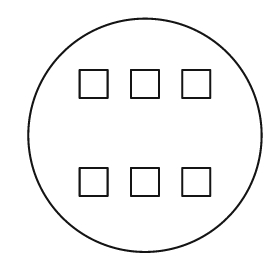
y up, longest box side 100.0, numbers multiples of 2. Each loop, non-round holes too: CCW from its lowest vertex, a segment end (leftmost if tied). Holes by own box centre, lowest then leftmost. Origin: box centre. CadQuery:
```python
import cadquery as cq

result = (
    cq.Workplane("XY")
    .moveTo(0.0, 0.0)
    .circle(50.0)
    .moveTo(-28.0, -26.0)
    .lineTo(-16.0, -26.0)
    .lineTo(-16.0, -14.0)
    .lineTo(-28.0, -14.0)
    .close()
    .moveTo(-6.0, -26.0)
    .lineTo(6.0, -26.0)
    .lineTo(6.0, -14.0)
    .lineTo(-6.0, -14.0)
    .close()
    .moveTo(16.0, -26.0)
    .lineTo(28.0, -26.0)
    .lineTo(28.0, -14.0)
    .lineTo(16.0, -14.0)
    .close()
    .moveTo(-28.0, 16.0)
    .lineTo(-16.0, 16.0)
    .lineTo(-16.0, 28.0)
    .lineTo(-28.0, 28.0)
    .close()
    .moveTo(-6.0, 16.0)
    .lineTo(6.0, 16.0)
    .lineTo(6.0, 28.0)
    .lineTo(-6.0, 28.0)
    .close()
    .moveTo(16.0, 16.0)
    .lineTo(28.0, 16.0)
    .lineTo(28.0, 28.0)
    .lineTo(16.0, 28.0)
    .close()
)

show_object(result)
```